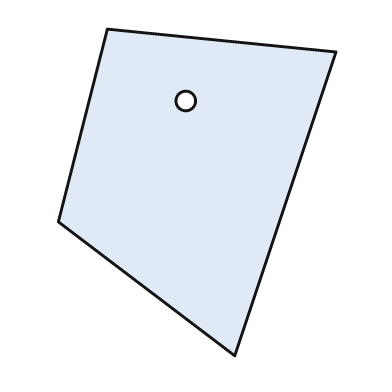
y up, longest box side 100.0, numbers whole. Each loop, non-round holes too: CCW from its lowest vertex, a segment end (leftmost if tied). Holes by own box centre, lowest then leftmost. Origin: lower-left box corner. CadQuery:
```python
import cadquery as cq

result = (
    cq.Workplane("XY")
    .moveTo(54.0, 0.0)
    .lineTo(85.0, 93.0)
    .lineTo(15.0, 100.0)
    .lineTo(0.0, 41.0)
    .close()
    .moveTo(39.0, 78.0)
    .circle(3.0)
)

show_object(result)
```